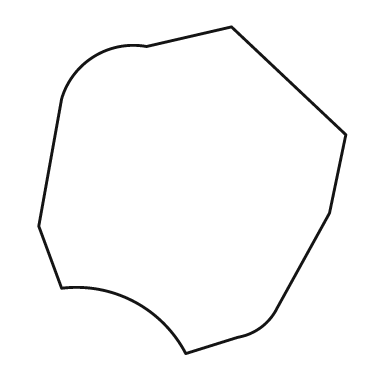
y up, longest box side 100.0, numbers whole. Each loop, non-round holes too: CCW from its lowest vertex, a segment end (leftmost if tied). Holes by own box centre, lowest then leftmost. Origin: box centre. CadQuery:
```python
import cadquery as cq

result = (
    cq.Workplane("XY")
    .moveTo(-2.0, -50.0)
    .lineTo(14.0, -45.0)
    .threePointArc((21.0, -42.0), (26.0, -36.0))
    .lineTo(42.0, -7.0)
    .lineTo(47.0, 17.0)
    .lineTo(12.0, 50.0)
    .lineTo(-14.0, 44.0)
    .threePointArc((-30.0, 41.0), (-40.0, 28.0))
    .lineTo(-47.0, -11.0)
    .lineTo(-40.0, -30.0)
    .threePointArc((-18.0, -34.0), (-2.0, -50.0))
    .close()
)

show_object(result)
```